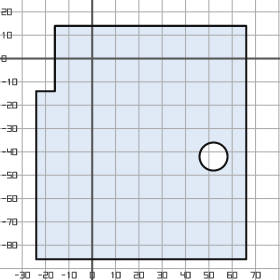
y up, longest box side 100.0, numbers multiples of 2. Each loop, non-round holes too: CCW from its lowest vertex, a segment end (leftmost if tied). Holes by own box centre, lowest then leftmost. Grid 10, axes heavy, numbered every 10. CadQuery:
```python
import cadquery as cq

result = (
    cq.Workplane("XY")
    .moveTo(-24.0, -86.0)
    .lineTo(66.0, -86.0)
    .lineTo(66.0, 14.0)
    .lineTo(-16.0, 14.0)
    .lineTo(-16.0, -14.0)
    .lineTo(-24.0, -14.0)
    .close()
    .moveTo(52.0, -42.0)
    .circle(6.0)
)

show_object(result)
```